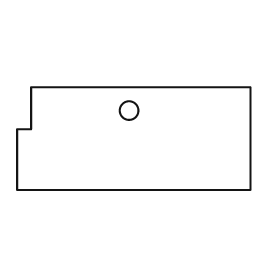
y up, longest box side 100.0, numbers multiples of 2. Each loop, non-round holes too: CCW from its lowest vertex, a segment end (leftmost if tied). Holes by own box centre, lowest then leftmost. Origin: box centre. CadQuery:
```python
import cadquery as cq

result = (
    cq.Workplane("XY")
    .moveTo(-50.0, -22.0)
    .lineTo(50.0, -22.0)
    .lineTo(50.0, 22.0)
    .lineTo(-44.0, 22.0)
    .lineTo(-44.0, 4.0)
    .lineTo(-50.0, 4.0)
    .close()
    .moveTo(-2.0, 12.0)
    .circle(4.0)
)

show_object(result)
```